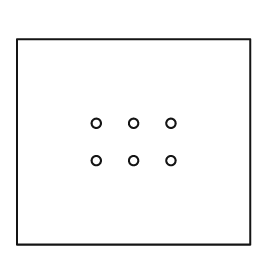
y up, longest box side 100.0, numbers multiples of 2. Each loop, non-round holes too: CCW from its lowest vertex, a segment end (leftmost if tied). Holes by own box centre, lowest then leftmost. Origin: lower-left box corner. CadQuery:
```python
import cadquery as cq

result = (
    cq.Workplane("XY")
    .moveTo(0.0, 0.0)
    .lineTo(100.0, 0.0)
    .lineTo(100.0, 88.0)
    .lineTo(0.0, 88.0)
    .close()
    .moveTo(34.0, 36.0)
    .circle(2.0)
    .moveTo(50.0, 36.0)
    .circle(2.0)
    .moveTo(66.0, 36.0)
    .circle(2.0)
    .moveTo(34.0, 52.0)
    .circle(2.0)
    .moveTo(50.0, 52.0)
    .circle(2.0)
    .moveTo(66.0, 52.0)
    .circle(2.0)
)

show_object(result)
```